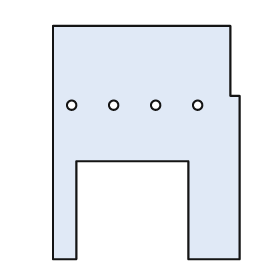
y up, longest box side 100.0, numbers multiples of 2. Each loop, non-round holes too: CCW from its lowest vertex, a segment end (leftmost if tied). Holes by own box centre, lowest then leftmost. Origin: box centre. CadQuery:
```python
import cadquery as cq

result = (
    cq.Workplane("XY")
    .moveTo(-40.0, -50.0)
    .lineTo(-30.0, -50.0)
    .lineTo(-30.0, -8.0)
    .lineTo(18.0, -8.0)
    .lineTo(18.0, -50.0)
    .lineTo(40.0, -50.0)
    .lineTo(40.0, 20.0)
    .lineTo(36.0, 20.0)
    .lineTo(36.0, 50.0)
    .lineTo(-40.0, 50.0)
    .close()
    .moveTo(-32.0, 16.0)
    .circle(2.0)
    .moveTo(-14.0, 16.0)
    .circle(2.0)
    .moveTo(4.0, 16.0)
    .circle(2.0)
    .moveTo(22.0, 16.0)
    .circle(2.0)
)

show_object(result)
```